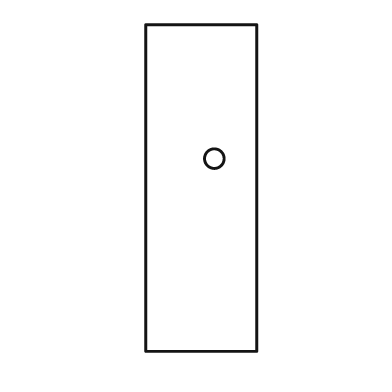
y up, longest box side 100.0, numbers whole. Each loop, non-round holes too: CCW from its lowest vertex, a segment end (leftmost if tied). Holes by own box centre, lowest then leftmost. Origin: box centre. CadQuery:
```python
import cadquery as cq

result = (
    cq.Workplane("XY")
    .moveTo(-17.0, -50.0)
    .lineTo(17.0, -50.0)
    .lineTo(17.0, 50.0)
    .lineTo(-17.0, 50.0)
    .close()
    .moveTo(4.0, 9.0)
    .circle(3.0)
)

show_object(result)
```